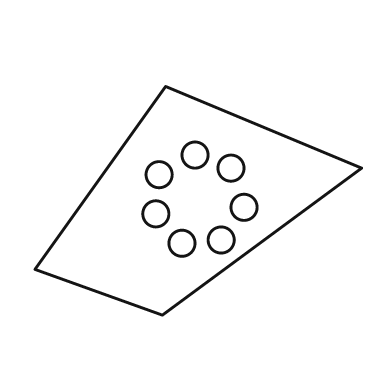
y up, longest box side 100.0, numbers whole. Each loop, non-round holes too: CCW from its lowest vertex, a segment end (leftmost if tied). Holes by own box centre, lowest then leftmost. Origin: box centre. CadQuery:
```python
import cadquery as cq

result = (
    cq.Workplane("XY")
    .moveTo(-11.0, -35.0)
    .lineTo(50.0, 10.0)
    .lineTo(-10.0, 35.0)
    .lineTo(-50.0, -21.0)
    .close()
    .moveTo(-5.0, -13.0)
    .circle(4.0)
    .moveTo(7.0, -12.0)
    .circle(4.0)
    .moveTo(-13.0, -4.0)
    .circle(4.0)
    .moveTo(14.0, -2.0)
    .circle(4.0)
    .moveTo(-12.0, 8.0)
    .circle(4.0)
    .moveTo(10.0, 10.0)
    .circle(4.0)
    .moveTo(-1.0, 14.0)
    .circle(4.0)
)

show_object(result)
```